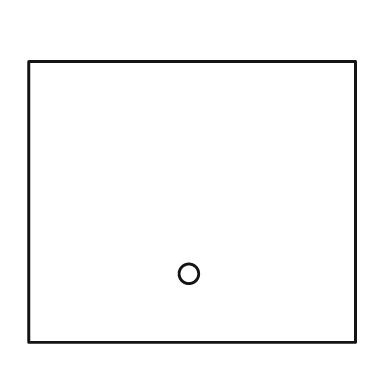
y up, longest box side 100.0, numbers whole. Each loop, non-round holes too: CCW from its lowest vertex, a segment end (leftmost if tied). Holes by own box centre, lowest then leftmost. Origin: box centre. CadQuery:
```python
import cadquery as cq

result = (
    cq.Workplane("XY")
    .moveTo(-50.0, -43.0)
    .lineTo(50.0, -43.0)
    .lineTo(50.0, 43.0)
    .lineTo(-50.0, 43.0)
    .close()
    .moveTo(-1.0, -22.0)
    .circle(3.0)
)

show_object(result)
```